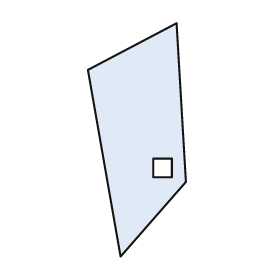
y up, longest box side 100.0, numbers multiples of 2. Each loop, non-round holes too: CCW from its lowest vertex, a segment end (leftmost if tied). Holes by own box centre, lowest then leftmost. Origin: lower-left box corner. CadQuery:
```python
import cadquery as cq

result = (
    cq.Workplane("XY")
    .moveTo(14.0, 0.0)
    .lineTo(42.0, 32.0)
    .lineTo(38.0, 100.0)
    .lineTo(0.0, 80.0)
    .close()
    .moveTo(28.0, 34.0)
    .lineTo(36.0, 34.0)
    .lineTo(36.0, 42.0)
    .lineTo(28.0, 42.0)
    .close()
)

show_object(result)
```